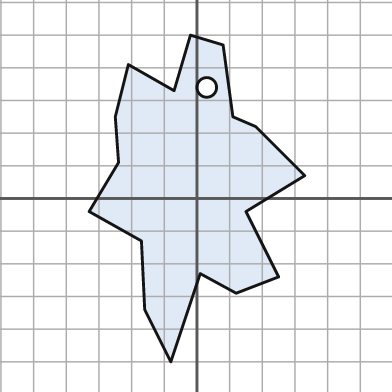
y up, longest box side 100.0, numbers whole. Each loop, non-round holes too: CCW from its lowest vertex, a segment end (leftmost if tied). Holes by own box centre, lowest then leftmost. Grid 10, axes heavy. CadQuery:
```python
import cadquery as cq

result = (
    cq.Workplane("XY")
    .moveTo(-8.0, -50.0)
    .lineTo(1.0, -23.0)
    .lineTo(12.0, -29.0)
    .lineTo(25.0, -24.0)
    .lineTo(15.0, -4.0)
    .lineTo(33.0, 7.0)
    .lineTo(18.0, 22.0)
    .lineTo(11.0, 25.0)
    .lineTo(8.0, 47.0)
    .lineTo(-2.0, 50.0)
    .lineTo(-7.0, 33.0)
    .lineTo(-21.0, 41.0)
    .lineTo(-25.0, 25.0)
    .lineTo(-24.0, 11.0)
    .lineTo(-33.0, -4.0)
    .lineTo(-17.0, -13.0)
    .lineTo(-16.0, -34.0)
    .close()
    .moveTo(3.0, 34.0)
    .circle(3.0)
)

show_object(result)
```